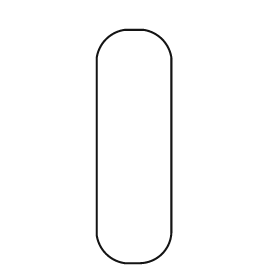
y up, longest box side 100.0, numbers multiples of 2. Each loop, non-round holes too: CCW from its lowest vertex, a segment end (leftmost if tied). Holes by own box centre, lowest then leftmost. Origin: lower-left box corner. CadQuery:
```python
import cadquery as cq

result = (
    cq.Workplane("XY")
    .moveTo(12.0, 0.0)
    .lineTo(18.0, 0.0)
    .threePointArc((28.0, 4.0), (32.0, 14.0))
    .lineTo(32.0, 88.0)
    .threePointArc((28.0, 96.0), (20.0, 100.0))
    .lineTo(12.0, 100.0)
    .threePointArc((4.0, 96.0), (0.0, 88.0))
    .lineTo(0.0, 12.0)
    .threePointArc((4.0, 4.0), (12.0, 0.0))
    .close()
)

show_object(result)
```